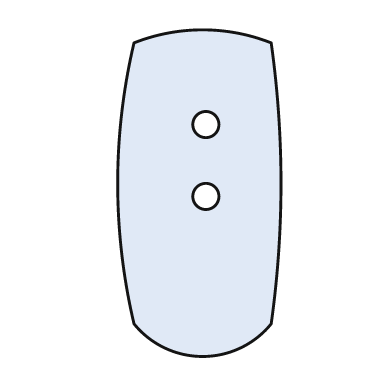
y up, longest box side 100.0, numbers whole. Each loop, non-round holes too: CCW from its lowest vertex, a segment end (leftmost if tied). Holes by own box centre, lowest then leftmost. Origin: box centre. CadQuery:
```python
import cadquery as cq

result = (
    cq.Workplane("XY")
    .moveTo(-20.0, -40.0)
    .threePointArc((1.0, -50.0), (22.0, -40.0))
    .threePointArc((25.0, 3.0), (22.0, 46.0))
    .threePointArc((1.0, 50.0), (-20.0, 46.0))
    .threePointArc((-25.0, 3.0), (-20.0, -40.0))
    .close()
    .moveTo(2.0, -1.0)
    .circle(4.0)
    .moveTo(2.0, 21.0)
    .circle(4.0)
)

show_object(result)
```